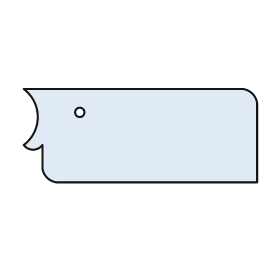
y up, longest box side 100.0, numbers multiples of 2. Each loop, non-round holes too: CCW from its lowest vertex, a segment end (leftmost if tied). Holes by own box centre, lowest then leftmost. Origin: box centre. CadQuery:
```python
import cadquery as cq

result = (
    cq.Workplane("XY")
    .moveTo(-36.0, -20.0)
    .lineTo(50.0, -20.0)
    .lineTo(50.0, 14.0)
    .threePointArc((48.0, 18.0), (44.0, 20.0))
    .lineTo(-50.0, 20.0)
    .threePointArc((-44.0, 8.0), (-50.0, -4.0))
    .threePointArc((-46.0, -6.0), (-42.0, -4.0))
    .lineTo(-42.0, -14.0)
    .threePointArc((-40.0, -18.0), (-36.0, -20.0))
    .close()
    .moveTo(-26.0, 10.0)
    .circle(2.0)
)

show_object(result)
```